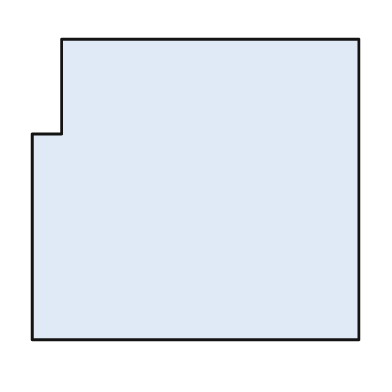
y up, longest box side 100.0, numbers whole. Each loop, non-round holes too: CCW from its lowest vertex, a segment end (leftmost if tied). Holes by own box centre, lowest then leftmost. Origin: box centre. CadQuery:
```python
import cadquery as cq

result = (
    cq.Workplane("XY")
    .moveTo(-50.0, -46.0)
    .lineTo(50.0, -46.0)
    .lineTo(50.0, 46.0)
    .lineTo(-41.0, 46.0)
    .lineTo(-41.0, 17.0)
    .lineTo(-50.0, 17.0)
    .close()
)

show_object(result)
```